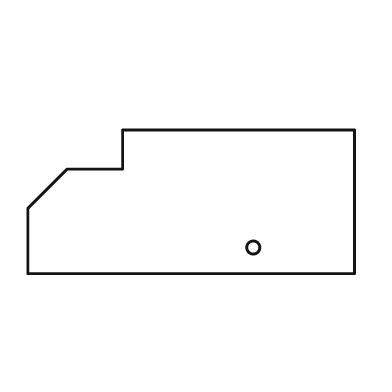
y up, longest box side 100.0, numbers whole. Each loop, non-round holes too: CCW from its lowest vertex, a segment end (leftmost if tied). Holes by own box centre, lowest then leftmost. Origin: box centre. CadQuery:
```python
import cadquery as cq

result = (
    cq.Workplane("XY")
    .moveTo(-50.0, -22.0)
    .lineTo(50.0, -22.0)
    .lineTo(50.0, 22.0)
    .lineTo(-21.0, 22.0)
    .lineTo(-21.0, 10.0)
    .lineTo(-38.0, 10.0)
    .lineTo(-50.0, -2.0)
    .close()
    .moveTo(19.0, -14.0)
    .circle(2.0)
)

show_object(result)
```